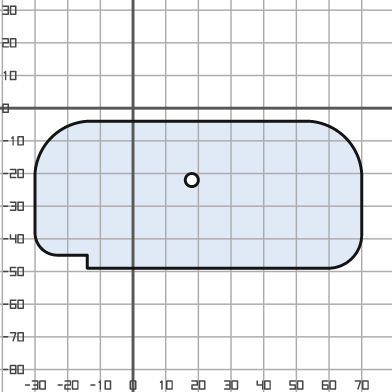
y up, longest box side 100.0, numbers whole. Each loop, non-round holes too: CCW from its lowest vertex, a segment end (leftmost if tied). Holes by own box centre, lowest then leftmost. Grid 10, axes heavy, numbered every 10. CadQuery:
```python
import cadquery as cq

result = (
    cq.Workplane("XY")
    .moveTo(-14.0, -49.0)
    .lineTo(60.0, -49.0)
    .threePointArc((67.0, -46.0), (70.0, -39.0))
    .lineTo(70.0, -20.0)
    .threePointArc((65.0, -9.0), (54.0, -4.0))
    .lineTo(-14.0, -4.0)
    .threePointArc((-25.0, -9.0), (-30.0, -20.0))
    .lineTo(-30.0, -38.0)
    .threePointArc((-28.0, -43.0), (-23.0, -45.0))
    .lineTo(-14.0, -45.0)
    .close()
    .moveTo(18.0, -22.0)
    .circle(2.0)
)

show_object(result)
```